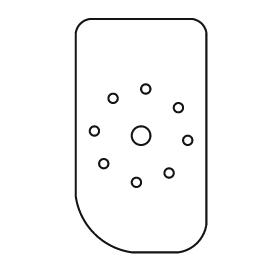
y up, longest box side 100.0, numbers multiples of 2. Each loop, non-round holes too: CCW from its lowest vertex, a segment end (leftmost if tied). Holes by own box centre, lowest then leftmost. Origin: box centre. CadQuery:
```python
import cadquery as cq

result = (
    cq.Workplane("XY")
    .moveTo(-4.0, -50.0)
    .lineTo(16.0, -50.0)
    .threePointArc((24.0, -46.0), (28.0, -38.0))
    .lineTo(28.0, 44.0)
    .threePointArc((26.0, 48.0), (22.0, 50.0))
    .lineTo(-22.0, 50.0)
    .threePointArc((-26.0, 48.0), (-28.0, 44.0))
    .lineTo(-28.0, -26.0)
    .threePointArc((-20.0, -42.0), (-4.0, -50.0))
    .close()
    .moveTo(-2.0, -20.0)
    .circle(2.0)
    .moveTo(12.0, -16.0)
    .circle(2.0)
    .moveTo(-16.0, -12.0)
    .circle(2.0)
    .moveTo(20.0, -2.0)
    .circle(2.0)
    .moveTo(0.0, 0.0)
    .circle(4.0)
    .moveTo(-20.0, 2.0)
    .circle(2.0)
    .moveTo(16.0, 12.0)
    .circle(2.0)
    .moveTo(-12.0, 16.0)
    .circle(2.0)
    .moveTo(2.0, 20.0)
    .circle(2.0)
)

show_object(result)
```